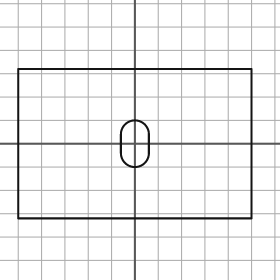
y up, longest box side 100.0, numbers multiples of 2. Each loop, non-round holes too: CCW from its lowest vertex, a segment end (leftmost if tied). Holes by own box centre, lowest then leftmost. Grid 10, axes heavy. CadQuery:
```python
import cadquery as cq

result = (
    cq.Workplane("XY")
    .moveTo(-50.0, -32.0)
    .lineTo(50.0, -32.0)
    .lineTo(50.0, 32.0)
    .lineTo(-50.0, 32.0)
    .close()
    .moveTo(-6.0, -4.0)
    .threePointArc((0.0, -10.0), (6.0, -4.0))
    .lineTo(6.0, 4.0)
    .threePointArc((0.0, 10.0), (-6.0, 4.0))
    .close()
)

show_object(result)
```